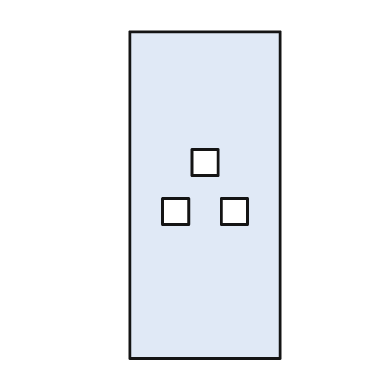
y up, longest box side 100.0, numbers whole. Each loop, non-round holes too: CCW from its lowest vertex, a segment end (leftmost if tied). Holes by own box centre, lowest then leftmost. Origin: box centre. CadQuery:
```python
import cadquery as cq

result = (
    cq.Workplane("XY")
    .moveTo(-23.0, -50.0)
    .lineTo(23.0, -50.0)
    .lineTo(23.0, 50.0)
    .lineTo(-23.0, 50.0)
    .close()
    .moveTo(-13.0, -9.0)
    .lineTo(-5.0, -9.0)
    .lineTo(-5.0, -1.0)
    .lineTo(-13.0, -1.0)
    .close()
    .moveTo(5.0, -9.0)
    .lineTo(13.0, -9.0)
    .lineTo(13.0, -1.0)
    .lineTo(5.0, -1.0)
    .close()
    .moveTo(-4.0, 6.0)
    .lineTo(4.0, 6.0)
    .lineTo(4.0, 14.0)
    .lineTo(-4.0, 14.0)
    .close()
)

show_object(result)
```